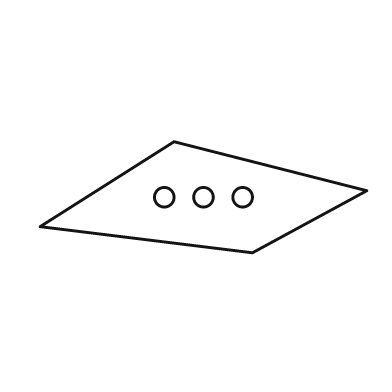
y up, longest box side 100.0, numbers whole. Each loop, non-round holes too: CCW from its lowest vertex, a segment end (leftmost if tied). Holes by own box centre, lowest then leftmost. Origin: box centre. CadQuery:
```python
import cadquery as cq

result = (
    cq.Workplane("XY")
    .moveTo(15.0, -17.0)
    .lineTo(50.0, 2.0)
    .lineTo(-9.0, 17.0)
    .lineTo(-50.0, -9.0)
    .close()
    .moveTo(-12.0, 0.0)
    .circle(3.0)
    .moveTo(0.0, 0.0)
    .circle(3.0)
    .moveTo(12.0, 0.0)
    .circle(3.0)
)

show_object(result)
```